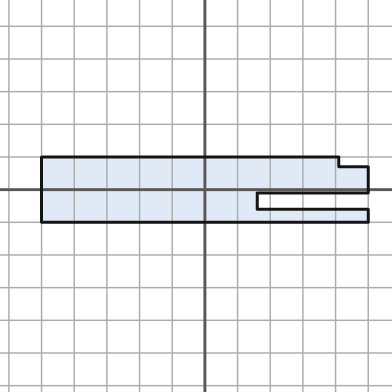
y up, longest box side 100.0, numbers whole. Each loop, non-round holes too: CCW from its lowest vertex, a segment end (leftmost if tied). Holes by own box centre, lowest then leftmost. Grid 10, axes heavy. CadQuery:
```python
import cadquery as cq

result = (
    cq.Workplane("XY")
    .moveTo(-50.0, -10.0)
    .lineTo(50.0, -10.0)
    .lineTo(50.0, -6.0)
    .lineTo(16.0, -6.0)
    .lineTo(16.0, -1.0)
    .lineTo(50.0, -1.0)
    .lineTo(50.0, 7.0)
    .lineTo(41.0, 7.0)
    .lineTo(41.0, 10.0)
    .lineTo(-50.0, 10.0)
    .close()
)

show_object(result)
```